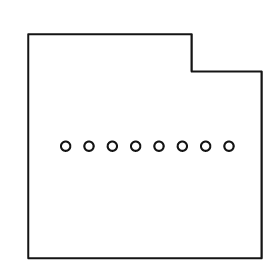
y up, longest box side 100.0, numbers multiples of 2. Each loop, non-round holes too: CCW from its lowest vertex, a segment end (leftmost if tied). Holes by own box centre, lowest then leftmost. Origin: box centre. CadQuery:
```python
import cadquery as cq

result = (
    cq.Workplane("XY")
    .moveTo(-50.0, -48.0)
    .lineTo(50.0, -48.0)
    .lineTo(50.0, 32.0)
    .lineTo(20.0, 32.0)
    .lineTo(20.0, 48.0)
    .lineTo(-50.0, 48.0)
    .close()
    .moveTo(-34.0, 0.0)
    .circle(2.0)
    .moveTo(-24.0, 0.0)
    .circle(2.0)
    .moveTo(-14.0, 0.0)
    .circle(2.0)
    .moveTo(-4.0, 0.0)
    .circle(2.0)
    .moveTo(6.0, 0.0)
    .circle(2.0)
    .moveTo(16.0, 0.0)
    .circle(2.0)
    .moveTo(26.0, 0.0)
    .circle(2.0)
    .moveTo(36.0, 0.0)
    .circle(2.0)
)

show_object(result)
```